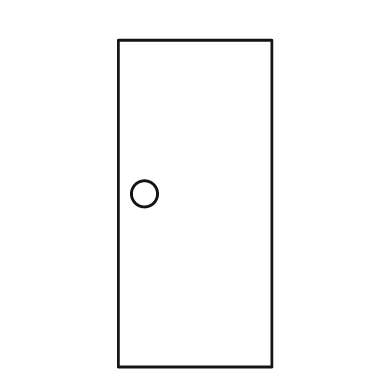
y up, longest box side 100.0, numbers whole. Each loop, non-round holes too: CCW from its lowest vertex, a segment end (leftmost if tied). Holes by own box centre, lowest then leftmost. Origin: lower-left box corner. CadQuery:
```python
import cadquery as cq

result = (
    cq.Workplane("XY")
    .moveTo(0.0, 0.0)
    .lineTo(47.0, 0.0)
    .lineTo(47.0, 100.0)
    .lineTo(0.0, 100.0)
    .close()
    .moveTo(8.0, 53.0)
    .circle(4.0)
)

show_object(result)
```